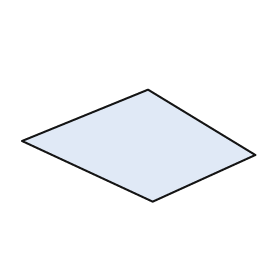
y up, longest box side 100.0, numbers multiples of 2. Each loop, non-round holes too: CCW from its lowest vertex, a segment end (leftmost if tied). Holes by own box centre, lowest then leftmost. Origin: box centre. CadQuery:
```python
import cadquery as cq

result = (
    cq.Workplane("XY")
    .moveTo(6.0, -24.0)
    .lineTo(50.0, -4.0)
    .lineTo(4.0, 24.0)
    .lineTo(-50.0, 2.0)
    .close()
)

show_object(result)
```